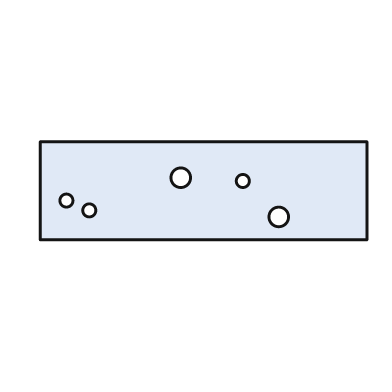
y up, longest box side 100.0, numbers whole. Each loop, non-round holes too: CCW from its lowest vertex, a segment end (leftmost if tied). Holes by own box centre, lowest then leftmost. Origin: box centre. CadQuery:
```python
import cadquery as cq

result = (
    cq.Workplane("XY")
    .moveTo(-50.0, -15.0)
    .lineTo(50.0, -15.0)
    .lineTo(50.0, 15.0)
    .lineTo(-50.0, 15.0)
    .close()
    .moveTo(23.0, -8.0)
    .circle(3.0)
    .moveTo(-35.0, -6.0)
    .circle(2.0)
    .moveTo(-42.0, -3.0)
    .circle(2.0)
    .moveTo(12.0, 3.0)
    .circle(2.0)
    .moveTo(-7.0, 4.0)
    .circle(3.0)
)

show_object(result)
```